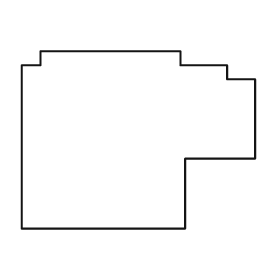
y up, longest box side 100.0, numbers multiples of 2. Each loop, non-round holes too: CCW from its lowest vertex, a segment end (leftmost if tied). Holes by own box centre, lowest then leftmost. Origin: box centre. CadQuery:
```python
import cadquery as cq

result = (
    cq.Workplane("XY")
    .moveTo(-50.0, -38.0)
    .lineTo(20.0, -38.0)
    .lineTo(20.0, -8.0)
    .lineTo(50.0, -8.0)
    .lineTo(50.0, 26.0)
    .lineTo(38.0, 26.0)
    .lineTo(38.0, 32.0)
    .lineTo(18.0, 32.0)
    .lineTo(18.0, 38.0)
    .lineTo(-42.0, 38.0)
    .lineTo(-42.0, 32.0)
    .lineTo(-50.0, 32.0)
    .close()
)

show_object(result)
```